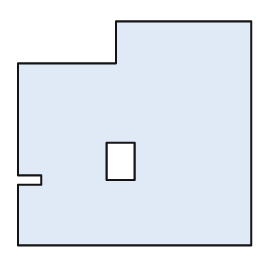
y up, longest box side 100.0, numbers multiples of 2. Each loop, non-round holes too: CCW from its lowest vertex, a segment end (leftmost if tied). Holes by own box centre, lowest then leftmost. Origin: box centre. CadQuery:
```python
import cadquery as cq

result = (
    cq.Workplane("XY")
    .moveTo(-50.0, -48.0)
    .lineTo(50.0, -48.0)
    .lineTo(50.0, 48.0)
    .lineTo(-8.0, 48.0)
    .lineTo(-8.0, 30.0)
    .lineTo(-50.0, 30.0)
    .lineTo(-50.0, -18.0)
    .lineTo(-40.0, -18.0)
    .lineTo(-40.0, -22.0)
    .lineTo(-50.0, -22.0)
    .close()
    .moveTo(-12.0, -20.0)
    .lineTo(0.0, -20.0)
    .lineTo(0.0, -4.0)
    .lineTo(-12.0, -4.0)
    .close()
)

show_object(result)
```